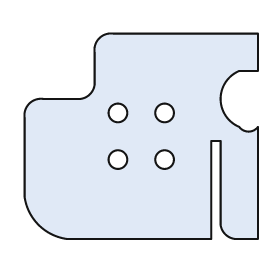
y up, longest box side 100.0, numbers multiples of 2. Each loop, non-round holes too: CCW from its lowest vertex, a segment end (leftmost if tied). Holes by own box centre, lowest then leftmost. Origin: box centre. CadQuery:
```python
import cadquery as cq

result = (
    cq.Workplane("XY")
    .moveTo(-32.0, -44.0)
    .lineTo(30.0, -44.0)
    .lineTo(30.0, -2.0)
    .lineTo(34.0, -2.0)
    .lineTo(34.0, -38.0)
    .threePointArc((36.0, -42.0), (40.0, -44.0))
    .lineTo(50.0, -44.0)
    .lineTo(50.0, 4.0)
    .threePointArc((46.0, 2.0), (42.0, 4.0))
    .threePointArc((34.0, 16.0), (42.0, 28.0))
    .lineTo(50.0, 28.0)
    .lineTo(50.0, 44.0)
    .lineTo(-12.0, 44.0)
    .threePointArc((-18.0, 42.0), (-20.0, 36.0))
    .lineTo(-20.0, 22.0)
    .threePointArc((-22.0, 18.0), (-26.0, 16.0))
    .lineTo(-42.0, 16.0)
    .threePointArc((-48.0, 14.0), (-50.0, 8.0))
    .lineTo(-50.0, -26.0)
    .threePointArc((-44.0, -38.0), (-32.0, -44.0))
    .close()
    .moveTo(-10.0, -10.0)
    .circle(4.0)
    .moveTo(10.0, -10.0)
    .circle(4.0)
    .moveTo(-10.0, 10.0)
    .circle(4.0)
    .moveTo(10.0, 10.0)
    .circle(4.0)
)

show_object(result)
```